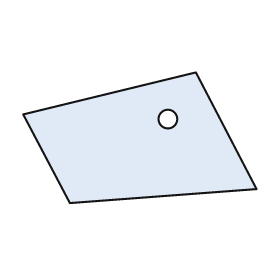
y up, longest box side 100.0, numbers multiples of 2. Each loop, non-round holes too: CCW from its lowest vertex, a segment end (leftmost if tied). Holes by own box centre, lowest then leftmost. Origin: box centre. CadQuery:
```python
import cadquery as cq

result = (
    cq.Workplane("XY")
    .moveTo(-30.0, -28.0)
    .lineTo(50.0, -22.0)
    .lineTo(24.0, 28.0)
    .lineTo(-50.0, 10.0)
    .close()
    .moveTo(12.0, 8.0)
    .circle(4.0)
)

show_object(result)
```